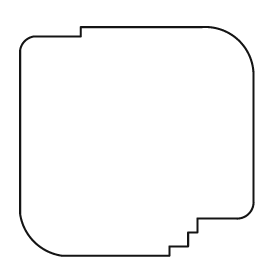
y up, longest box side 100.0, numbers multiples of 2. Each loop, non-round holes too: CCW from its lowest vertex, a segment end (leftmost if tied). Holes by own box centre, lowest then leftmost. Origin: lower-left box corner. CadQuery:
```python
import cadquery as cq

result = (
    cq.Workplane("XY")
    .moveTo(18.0, 0.0)
    .lineTo(64.0, 0.0)
    .lineTo(64.0, 4.0)
    .lineTo(72.0, 4.0)
    .lineTo(72.0, 10.0)
    .lineTo(76.0, 10.0)
    .lineTo(76.0, 16.0)
    .lineTo(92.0, 16.0)
    .threePointArc((98.0, 18.0), (100.0, 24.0))
    .lineTo(100.0, 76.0)
    .threePointArc((94.0, 92.0), (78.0, 98.0))
    .lineTo(26.0, 98.0)
    .lineTo(26.0, 94.0)
    .lineTo(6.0, 94.0)
    .threePointArc((2.0, 92.0), (0.0, 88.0))
    .lineTo(0.0, 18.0)
    .threePointArc((6.0, 6.0), (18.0, 0.0))
    .close()
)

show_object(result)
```